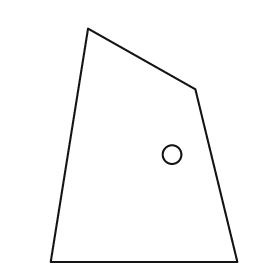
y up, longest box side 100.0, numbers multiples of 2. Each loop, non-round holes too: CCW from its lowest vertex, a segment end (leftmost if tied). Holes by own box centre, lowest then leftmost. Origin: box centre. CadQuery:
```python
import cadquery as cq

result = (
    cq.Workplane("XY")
    .moveTo(-40.0, -50.0)
    .lineTo(40.0, -50.0)
    .lineTo(22.0, 24.0)
    .lineTo(-24.0, 50.0)
    .close()
    .moveTo(12.0, -4.0)
    .circle(4.0)
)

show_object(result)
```